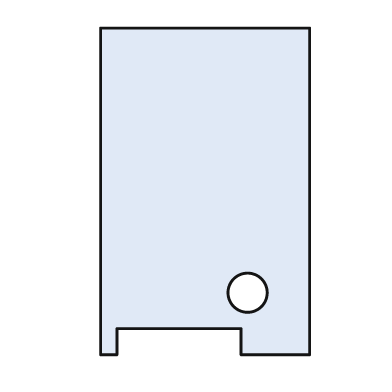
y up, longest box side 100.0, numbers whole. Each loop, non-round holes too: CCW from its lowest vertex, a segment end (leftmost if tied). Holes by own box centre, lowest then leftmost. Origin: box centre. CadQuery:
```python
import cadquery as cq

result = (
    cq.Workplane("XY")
    .moveTo(-32.0, -50.0)
    .lineTo(-27.0, -50.0)
    .lineTo(-27.0, -42.0)
    .lineTo(11.0, -42.0)
    .lineTo(11.0, -50.0)
    .lineTo(32.0, -50.0)
    .lineTo(32.0, 50.0)
    .lineTo(-32.0, 50.0)
    .close()
    .moveTo(13.0, -31.0)
    .circle(6.0)
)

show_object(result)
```